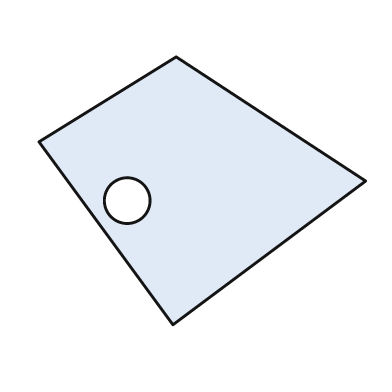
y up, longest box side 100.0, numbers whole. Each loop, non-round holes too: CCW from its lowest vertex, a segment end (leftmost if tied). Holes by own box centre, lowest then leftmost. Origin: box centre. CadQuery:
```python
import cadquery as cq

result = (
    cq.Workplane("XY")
    .moveTo(-9.0, -41.0)
    .lineTo(50.0, 3.0)
    .lineTo(-8.0, 41.0)
    .lineTo(-50.0, 15.0)
    .close()
    .moveTo(-23.0, -3.0)
    .circle(7.0)
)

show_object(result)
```